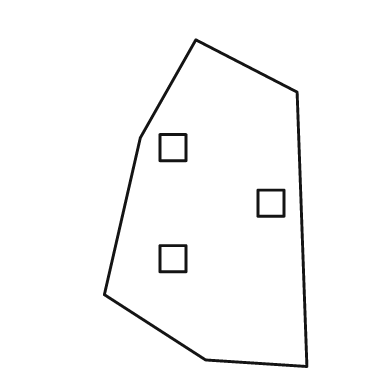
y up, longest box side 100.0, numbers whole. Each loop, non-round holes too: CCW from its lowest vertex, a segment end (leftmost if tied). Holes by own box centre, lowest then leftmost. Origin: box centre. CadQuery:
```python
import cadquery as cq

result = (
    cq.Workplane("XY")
    .moveTo(31.0, -50.0)
    .lineTo(28.0, 34.0)
    .lineTo(-3.0, 50.0)
    .lineTo(-20.0, 20.0)
    .lineTo(-31.0, -28.0)
    .lineTo(0.0, -48.0)
    .close()
    .moveTo(-14.0, -21.0)
    .lineTo(-6.0, -21.0)
    .lineTo(-6.0, -13.0)
    .lineTo(-14.0, -13.0)
    .close()
    .moveTo(16.0, -4.0)
    .lineTo(24.0, -4.0)
    .lineTo(24.0, 4.0)
    .lineTo(16.0, 4.0)
    .close()
    .moveTo(-14.0, 13.0)
    .lineTo(-6.0, 13.0)
    .lineTo(-6.0, 21.0)
    .lineTo(-14.0, 21.0)
    .close()
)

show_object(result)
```